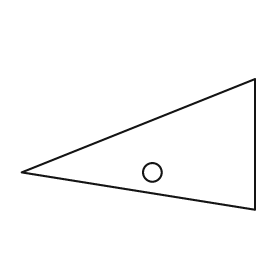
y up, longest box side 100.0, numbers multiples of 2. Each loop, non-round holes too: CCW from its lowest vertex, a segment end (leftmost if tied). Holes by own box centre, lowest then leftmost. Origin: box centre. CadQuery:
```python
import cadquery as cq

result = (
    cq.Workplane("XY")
    .moveTo(50.0, -28.0)
    .lineTo(50.0, 28.0)
    .lineTo(-50.0, -12.0)
    .close()
    .moveTo(6.0, -12.0)
    .circle(4.0)
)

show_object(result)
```